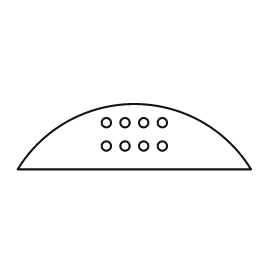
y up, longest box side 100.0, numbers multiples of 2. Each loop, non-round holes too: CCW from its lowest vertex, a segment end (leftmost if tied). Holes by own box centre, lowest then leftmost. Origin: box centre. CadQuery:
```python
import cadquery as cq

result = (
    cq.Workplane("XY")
    .moveTo(-50.0, -14.0)
    .lineTo(50.0, -14.0)
    .threePointArc((0.0, 14.0), (-50.0, -14.0))
    .close()
    .moveTo(-12.0, -4.0)
    .circle(2.0)
    .moveTo(-4.0, -4.0)
    .circle(2.0)
    .moveTo(4.0, -4.0)
    .circle(2.0)
    .moveTo(12.0, -4.0)
    .circle(2.0)
    .moveTo(-12.0, 6.0)
    .circle(2.0)
    .moveTo(-4.0, 6.0)
    .circle(2.0)
    .moveTo(4.0, 6.0)
    .circle(2.0)
    .moveTo(12.0, 6.0)
    .circle(2.0)
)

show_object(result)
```